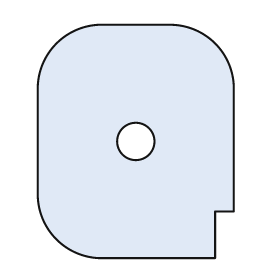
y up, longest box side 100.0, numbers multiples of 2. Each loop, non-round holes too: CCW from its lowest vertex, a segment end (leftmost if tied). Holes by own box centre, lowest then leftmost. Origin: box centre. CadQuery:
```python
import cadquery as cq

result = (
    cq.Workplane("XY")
    .moveTo(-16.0, -50.0)
    .lineTo(34.0, -50.0)
    .lineTo(34.0, -30.0)
    .lineTo(42.0, -30.0)
    .lineTo(42.0, 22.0)
    .threePointArc((34.0, 42.0), (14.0, 50.0))
    .lineTo(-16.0, 50.0)
    .threePointArc((-34.0, 42.0), (-42.0, 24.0))
    .lineTo(-42.0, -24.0)
    .threePointArc((-34.0, -42.0), (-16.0, -50.0))
    .close()
    .moveTo(0.0, 0.0)
    .circle(8.0)
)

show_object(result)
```